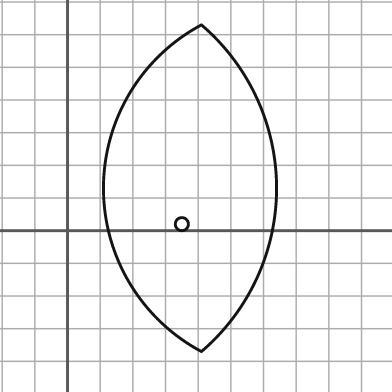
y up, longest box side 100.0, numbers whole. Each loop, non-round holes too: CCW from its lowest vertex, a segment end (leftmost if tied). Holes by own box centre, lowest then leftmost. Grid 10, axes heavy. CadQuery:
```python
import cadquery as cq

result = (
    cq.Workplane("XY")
    .moveTo(41.0, -37.0)
    .threePointArc((64.0, 13.0), (41.0, 63.0))
    .threePointArc((11.0, 13.0), (41.0, -37.0))
    .close()
    .moveTo(35.0, 2.0)
    .circle(2.0)
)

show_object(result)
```